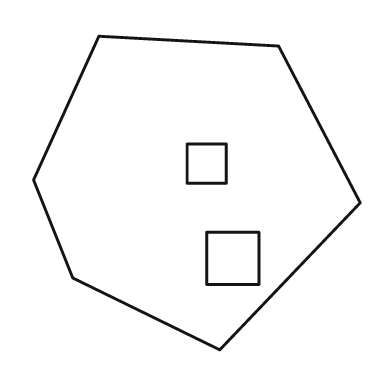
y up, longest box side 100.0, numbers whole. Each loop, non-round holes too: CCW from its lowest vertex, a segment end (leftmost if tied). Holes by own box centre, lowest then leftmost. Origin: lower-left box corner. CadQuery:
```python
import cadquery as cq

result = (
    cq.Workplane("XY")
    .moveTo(57.0, 0.0)
    .lineTo(100.0, 45.0)
    .lineTo(75.0, 93.0)
    .lineTo(20.0, 96.0)
    .lineTo(0.0, 52.0)
    .lineTo(12.0, 22.0)
    .close()
    .moveTo(53.0, 20.0)
    .lineTo(69.0, 20.0)
    .lineTo(69.0, 36.0)
    .lineTo(53.0, 36.0)
    .close()
    .moveTo(47.0, 51.0)
    .lineTo(59.0, 51.0)
    .lineTo(59.0, 63.0)
    .lineTo(47.0, 63.0)
    .close()
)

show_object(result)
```